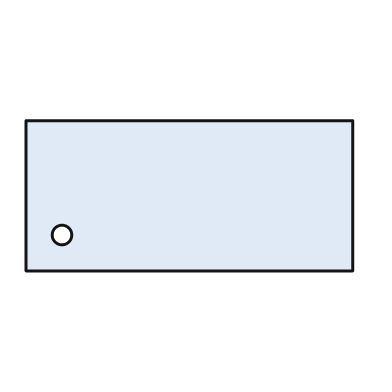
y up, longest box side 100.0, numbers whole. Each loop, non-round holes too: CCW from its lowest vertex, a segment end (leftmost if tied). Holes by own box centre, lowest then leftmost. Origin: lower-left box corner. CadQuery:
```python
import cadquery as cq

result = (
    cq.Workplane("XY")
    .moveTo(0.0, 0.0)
    .lineTo(100.0, 0.0)
    .lineTo(100.0, 46.0)
    .lineTo(0.0, 46.0)
    .close()
    .moveTo(11.0, 11.0)
    .circle(3.0)
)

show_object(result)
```